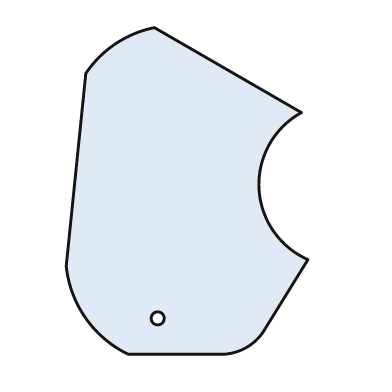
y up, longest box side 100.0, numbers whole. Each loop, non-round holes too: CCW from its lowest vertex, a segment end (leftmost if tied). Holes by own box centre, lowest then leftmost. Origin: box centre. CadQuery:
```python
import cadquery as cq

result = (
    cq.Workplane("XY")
    .moveTo(-18.0, -50.0)
    .lineTo(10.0, -50.0)
    .threePointArc((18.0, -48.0), (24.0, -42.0))
    .lineTo(37.0, -21.0)
    .threePointArc((22.0, 1.0), (35.0, 24.0))
    .lineTo(-10.0, 50.0)
    .threePointArc((-22.0, 45.0), (-31.0, 36.0))
    .lineTo(-37.0, -23.0)
    .threePointArc((-31.0, -39.0), (-18.0, -50.0))
    .close()
    .moveTo(-9.0, -39.0)
    .circle(2.0)
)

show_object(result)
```